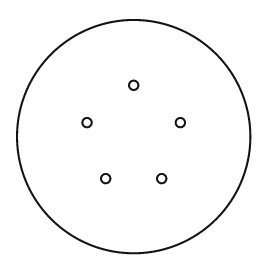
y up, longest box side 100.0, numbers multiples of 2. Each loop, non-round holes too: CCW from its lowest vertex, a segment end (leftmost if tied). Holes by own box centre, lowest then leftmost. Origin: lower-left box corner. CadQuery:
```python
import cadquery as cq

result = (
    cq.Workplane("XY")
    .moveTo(50.0, 50.0)
    .circle(50.0)
    .moveTo(38.0, 32.0)
    .circle(2.0)
    .moveTo(62.0, 32.0)
    .circle(2.0)
    .moveTo(30.0, 56.0)
    .circle(2.0)
    .moveTo(70.0, 56.0)
    .circle(2.0)
    .moveTo(50.0, 72.0)
    .circle(2.0)
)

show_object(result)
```